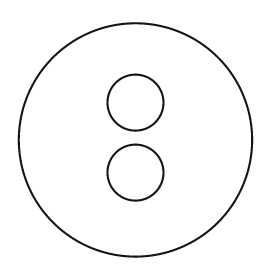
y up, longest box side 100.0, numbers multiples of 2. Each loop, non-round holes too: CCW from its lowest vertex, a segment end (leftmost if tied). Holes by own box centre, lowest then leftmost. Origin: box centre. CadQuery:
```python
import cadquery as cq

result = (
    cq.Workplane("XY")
    .moveTo(0.0, 0.0)
    .circle(50.0)
    .moveTo(0.0, -14.0)
    .circle(12.0)
    .moveTo(0.0, 16.0)
    .circle(12.0)
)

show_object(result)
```